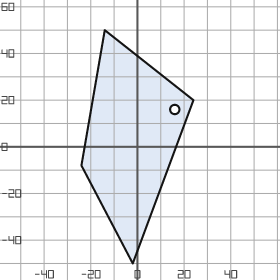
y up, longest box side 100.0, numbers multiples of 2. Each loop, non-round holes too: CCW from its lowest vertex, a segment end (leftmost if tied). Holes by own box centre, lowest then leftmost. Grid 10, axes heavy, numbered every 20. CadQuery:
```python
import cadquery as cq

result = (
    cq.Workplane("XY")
    .moveTo(-2.0, -50.0)
    .lineTo(24.0, 20.0)
    .lineTo(-14.0, 50.0)
    .lineTo(-24.0, -8.0)
    .close()
    .moveTo(16.0, 16.0)
    .circle(2.0)
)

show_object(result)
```